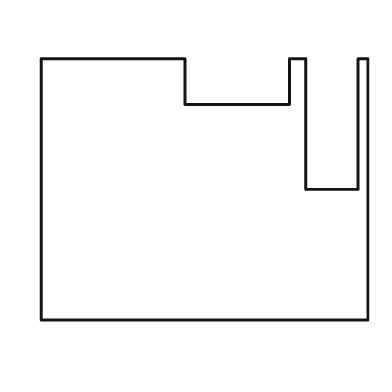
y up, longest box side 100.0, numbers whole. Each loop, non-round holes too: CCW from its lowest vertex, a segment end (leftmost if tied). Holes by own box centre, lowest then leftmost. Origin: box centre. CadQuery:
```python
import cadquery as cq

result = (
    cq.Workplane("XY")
    .moveTo(-50.0, -40.0)
    .lineTo(50.0, -40.0)
    .lineTo(50.0, 40.0)
    .lineTo(47.0, 40.0)
    .lineTo(47.0, 0.0)
    .lineTo(31.0, 0.0)
    .lineTo(31.0, 40.0)
    .lineTo(26.0, 40.0)
    .lineTo(26.0, 26.0)
    .lineTo(-6.0, 26.0)
    .lineTo(-6.0, 40.0)
    .lineTo(-50.0, 40.0)
    .close()
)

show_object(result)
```